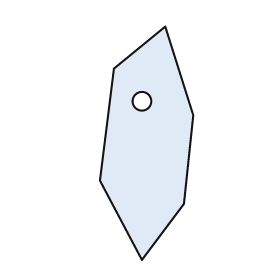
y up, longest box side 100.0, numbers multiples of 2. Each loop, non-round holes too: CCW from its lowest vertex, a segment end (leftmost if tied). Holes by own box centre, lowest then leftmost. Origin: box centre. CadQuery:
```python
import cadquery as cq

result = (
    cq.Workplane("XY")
    .moveTo(-2.0, -50.0)
    .lineTo(16.0, -26.0)
    .lineTo(20.0, 12.0)
    .lineTo(8.0, 50.0)
    .lineTo(-14.0, 32.0)
    .lineTo(-20.0, -16.0)
    .close()
    .moveTo(-2.0, 18.0)
    .circle(4.0)
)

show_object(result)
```